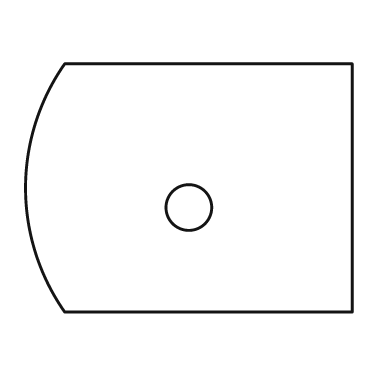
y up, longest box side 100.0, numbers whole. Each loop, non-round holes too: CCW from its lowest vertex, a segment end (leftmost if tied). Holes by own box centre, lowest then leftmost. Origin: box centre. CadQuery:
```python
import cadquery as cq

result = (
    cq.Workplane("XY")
    .moveTo(-38.0, -38.0)
    .lineTo(50.0, -38.0)
    .lineTo(50.0, 38.0)
    .lineTo(-38.0, 38.0)
    .threePointArc((-50.0, 0.0), (-38.0, -38.0))
    .close()
    .moveTo(0.0, -6.0)
    .circle(7.0)
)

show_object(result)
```